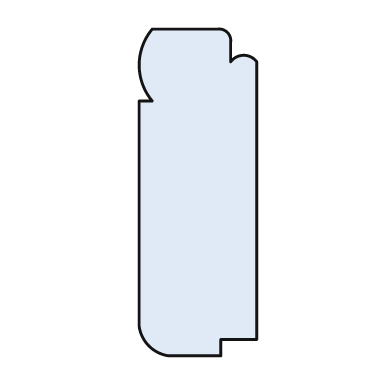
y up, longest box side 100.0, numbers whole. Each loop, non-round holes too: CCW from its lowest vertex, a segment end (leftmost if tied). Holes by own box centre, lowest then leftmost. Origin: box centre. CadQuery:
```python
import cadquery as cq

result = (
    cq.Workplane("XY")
    .moveTo(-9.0, -50.0)
    .lineTo(7.0, -50.0)
    .lineTo(7.0, -45.0)
    .lineTo(18.0, -45.0)
    .lineTo(18.0, 40.0)
    .threePointArc((14.0, 42.0), (10.0, 40.0))
    .lineTo(10.0, 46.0)
    .threePointArc((9.0, 49.0), (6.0, 50.0))
    .lineTo(-14.0, 50.0)
    .threePointArc((-18.0, 39.0), (-14.0, 28.0))
    .lineTo(-18.0, 28.0)
    .lineTo(-18.0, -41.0)
    .threePointArc((-15.0, -47.0), (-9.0, -50.0))
    .close()
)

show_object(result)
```